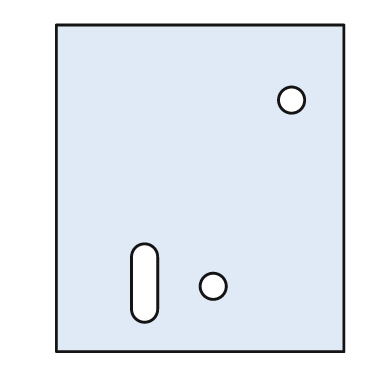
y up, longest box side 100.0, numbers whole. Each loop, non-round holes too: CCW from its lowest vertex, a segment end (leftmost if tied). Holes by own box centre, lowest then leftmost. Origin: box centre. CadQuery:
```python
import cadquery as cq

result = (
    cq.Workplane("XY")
    .moveTo(-44.0, -50.0)
    .lineTo(44.0, -50.0)
    .lineTo(44.0, 50.0)
    .lineTo(-44.0, 50.0)
    .close()
    .moveTo(4.0, -30.0)
    .circle(4.0)
    .moveTo(-21.0, -37.0)
    .threePointArc((-17.0, -41.0), (-13.0, -37.0))
    .lineTo(-13.0, -21.0)
    .threePointArc((-17.0, -17.0), (-21.0, -21.0))
    .close()
    .moveTo(28.0, 27.0)
    .circle(4.0)
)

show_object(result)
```